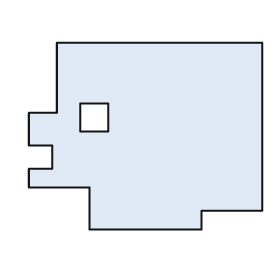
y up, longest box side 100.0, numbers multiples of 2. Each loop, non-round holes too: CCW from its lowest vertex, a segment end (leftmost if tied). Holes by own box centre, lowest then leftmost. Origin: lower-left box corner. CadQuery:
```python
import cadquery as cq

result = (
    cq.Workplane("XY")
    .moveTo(26.0, 0.0)
    .lineTo(74.0, 0.0)
    .lineTo(74.0, 8.0)
    .lineTo(100.0, 8.0)
    .lineTo(100.0, 80.0)
    .lineTo(12.0, 80.0)
    .lineTo(12.0, 50.0)
    .lineTo(0.0, 50.0)
    .lineTo(0.0, 36.0)
    .lineTo(10.0, 36.0)
    .lineTo(10.0, 26.0)
    .lineTo(0.0, 26.0)
    .lineTo(0.0, 18.0)
    .lineTo(26.0, 18.0)
    .close()
    .moveTo(22.0, 42.0)
    .lineTo(34.0, 42.0)
    .lineTo(34.0, 54.0)
    .lineTo(22.0, 54.0)
    .close()
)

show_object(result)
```